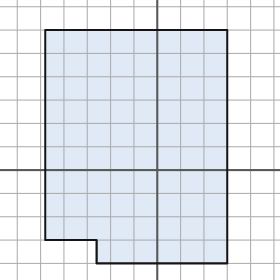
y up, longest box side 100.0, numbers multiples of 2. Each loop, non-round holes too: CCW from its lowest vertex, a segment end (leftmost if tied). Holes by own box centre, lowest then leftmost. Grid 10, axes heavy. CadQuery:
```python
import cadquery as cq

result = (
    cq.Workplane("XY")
    .moveTo(-26.0, -40.0)
    .lineTo(30.0, -40.0)
    .lineTo(30.0, 60.0)
    .lineTo(-48.0, 60.0)
    .lineTo(-48.0, -30.0)
    .lineTo(-26.0, -30.0)
    .close()
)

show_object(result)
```